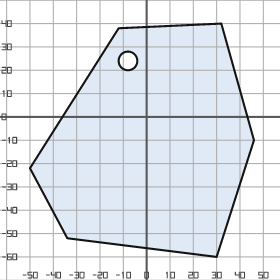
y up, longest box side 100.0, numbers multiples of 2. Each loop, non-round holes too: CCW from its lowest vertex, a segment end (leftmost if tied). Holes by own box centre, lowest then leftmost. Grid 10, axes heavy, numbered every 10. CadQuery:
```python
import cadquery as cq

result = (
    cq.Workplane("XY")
    .moveTo(30.0, -60.0)
    .lineTo(46.0, -10.0)
    .lineTo(32.0, 40.0)
    .lineTo(-12.0, 38.0)
    .lineTo(-50.0, -22.0)
    .lineTo(-34.0, -52.0)
    .close()
    .moveTo(-8.0, 24.0)
    .circle(4.0)
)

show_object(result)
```